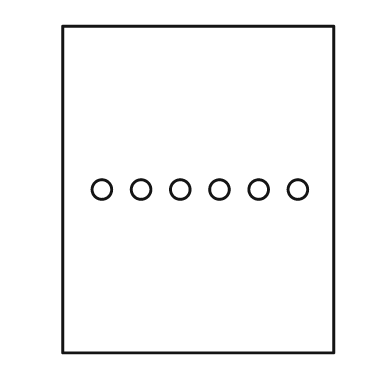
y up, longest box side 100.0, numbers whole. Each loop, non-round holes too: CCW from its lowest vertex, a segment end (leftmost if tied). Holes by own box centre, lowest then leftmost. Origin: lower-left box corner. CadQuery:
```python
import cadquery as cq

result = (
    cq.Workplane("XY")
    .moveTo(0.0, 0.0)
    .lineTo(83.0, 0.0)
    .lineTo(83.0, 100.0)
    .lineTo(0.0, 100.0)
    .close()
    .moveTo(12.0, 50.0)
    .circle(3.0)
    .moveTo(24.0, 50.0)
    .circle(3.0)
    .moveTo(36.0, 50.0)
    .circle(3.0)
    .moveTo(48.0, 50.0)
    .circle(3.0)
    .moveTo(60.0, 50.0)
    .circle(3.0)
    .moveTo(72.0, 50.0)
    .circle(3.0)
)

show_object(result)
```